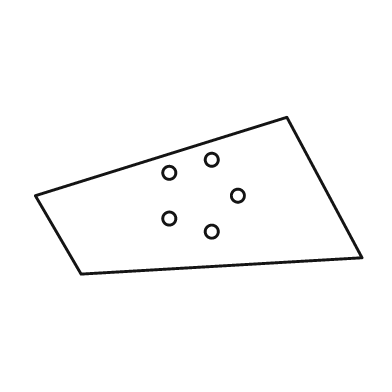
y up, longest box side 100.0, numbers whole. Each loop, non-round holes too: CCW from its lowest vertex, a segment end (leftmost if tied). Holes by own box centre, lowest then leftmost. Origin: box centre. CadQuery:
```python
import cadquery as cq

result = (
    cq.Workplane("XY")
    .moveTo(-36.0, -24.0)
    .lineTo(50.0, -19.0)
    .lineTo(27.0, 24.0)
    .lineTo(-50.0, 0.0)
    .close()
    .moveTo(4.0, -11.0)
    .circle(2.0)
    .moveTo(-9.0, -7.0)
    .circle(2.0)
    .moveTo(12.0, 0.0)
    .circle(2.0)
    .moveTo(-9.0, 7.0)
    .circle(2.0)
    .moveTo(4.0, 11.0)
    .circle(2.0)
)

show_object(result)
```